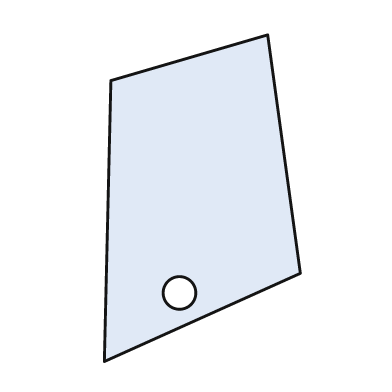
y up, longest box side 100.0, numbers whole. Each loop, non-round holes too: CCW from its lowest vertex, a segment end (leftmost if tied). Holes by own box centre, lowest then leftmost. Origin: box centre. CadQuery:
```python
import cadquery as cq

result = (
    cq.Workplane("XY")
    .moveTo(-30.0, -50.0)
    .lineTo(30.0, -23.0)
    .lineTo(20.0, 50.0)
    .lineTo(-28.0, 36.0)
    .close()
    .moveTo(-7.0, -29.0)
    .circle(5.0)
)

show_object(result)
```